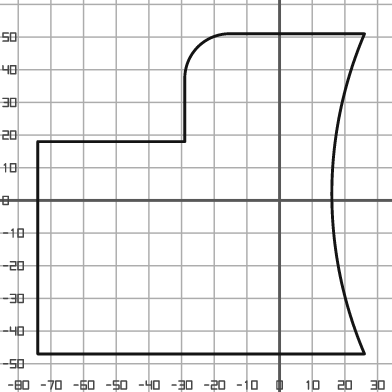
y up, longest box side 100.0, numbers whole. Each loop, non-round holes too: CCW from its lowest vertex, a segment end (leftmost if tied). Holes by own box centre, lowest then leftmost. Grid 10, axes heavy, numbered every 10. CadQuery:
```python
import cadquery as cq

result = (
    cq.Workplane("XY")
    .moveTo(-74.0, -47.0)
    .lineTo(26.0, -47.0)
    .threePointArc((16.0, 2.0), (26.0, 51.0))
    .lineTo(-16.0, 51.0)
    .threePointArc((-25.0, 47.0), (-29.0, 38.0))
    .lineTo(-29.0, 18.0)
    .lineTo(-74.0, 18.0)
    .close()
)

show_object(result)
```